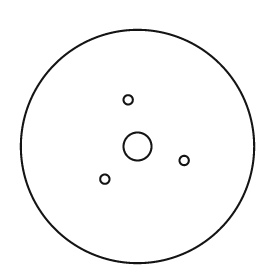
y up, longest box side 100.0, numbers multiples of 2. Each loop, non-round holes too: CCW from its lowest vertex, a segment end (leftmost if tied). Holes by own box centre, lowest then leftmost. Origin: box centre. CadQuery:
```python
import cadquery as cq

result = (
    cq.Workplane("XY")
    .moveTo(0.0, 0.0)
    .circle(50.0)
    .moveTo(-14.0, -14.0)
    .circle(2.0)
    .moveTo(20.0, -6.0)
    .circle(2.0)
    .moveTo(0.0, 0.0)
    .circle(6.0)
    .moveTo(-4.0, 20.0)
    .circle(2.0)
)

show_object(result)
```